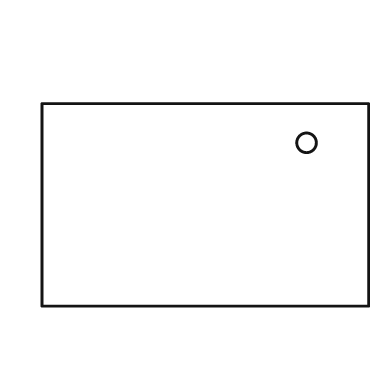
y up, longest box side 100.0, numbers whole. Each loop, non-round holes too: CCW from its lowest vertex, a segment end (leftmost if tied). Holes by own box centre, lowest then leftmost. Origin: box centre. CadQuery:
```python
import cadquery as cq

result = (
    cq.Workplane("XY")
    .moveTo(-50.0, -31.0)
    .lineTo(50.0, -31.0)
    .lineTo(50.0, 31.0)
    .lineTo(-50.0, 31.0)
    .close()
    .moveTo(31.0, 19.0)
    .circle(3.0)
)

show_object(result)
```